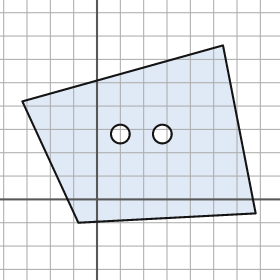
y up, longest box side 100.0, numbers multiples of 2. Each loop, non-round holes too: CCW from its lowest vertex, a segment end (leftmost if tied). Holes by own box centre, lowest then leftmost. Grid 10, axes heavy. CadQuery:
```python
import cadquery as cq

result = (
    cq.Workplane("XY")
    .moveTo(-8.0, -10.0)
    .lineTo(68.0, -6.0)
    .lineTo(54.0, 66.0)
    .lineTo(-32.0, 42.0)
    .close()
    .moveTo(10.0, 28.0)
    .circle(4.0)
    .moveTo(28.0, 28.0)
    .circle(4.0)
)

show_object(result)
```